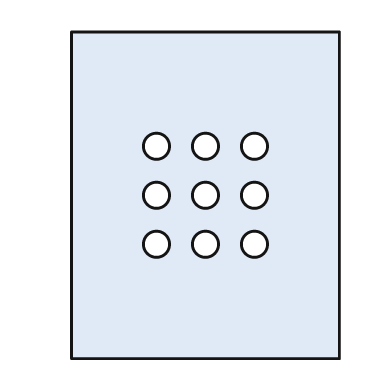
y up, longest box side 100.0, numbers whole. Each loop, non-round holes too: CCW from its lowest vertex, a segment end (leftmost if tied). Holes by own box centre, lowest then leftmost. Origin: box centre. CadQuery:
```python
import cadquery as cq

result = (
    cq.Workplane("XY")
    .moveTo(-41.0, -50.0)
    .lineTo(41.0, -50.0)
    .lineTo(41.0, 50.0)
    .lineTo(-41.0, 50.0)
    .close()
    .moveTo(-15.0, -15.0)
    .circle(4.0)
    .moveTo(0.0, -15.0)
    .circle(4.0)
    .moveTo(15.0, -15.0)
    .circle(4.0)
    .moveTo(-15.0, 0.0)
    .circle(4.0)
    .moveTo(0.0, 0.0)
    .circle(4.0)
    .moveTo(15.0, 0.0)
    .circle(4.0)
    .moveTo(-15.0, 15.0)
    .circle(4.0)
    .moveTo(0.0, 15.0)
    .circle(4.0)
    .moveTo(15.0, 15.0)
    .circle(4.0)
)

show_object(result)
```